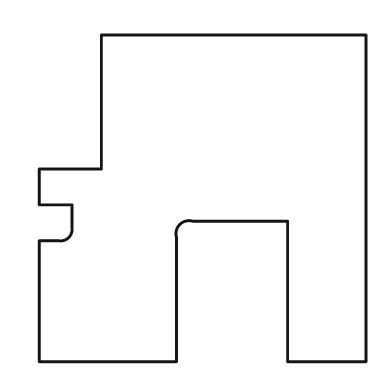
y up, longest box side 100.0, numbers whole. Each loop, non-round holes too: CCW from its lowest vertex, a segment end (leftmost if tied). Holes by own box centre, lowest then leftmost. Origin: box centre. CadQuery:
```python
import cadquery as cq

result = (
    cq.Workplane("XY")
    .moveTo(-50.0, -50.0)
    .lineTo(-8.0, -50.0)
    .lineTo(-8.0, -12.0)
    .threePointArc((-7.0, -8.0), (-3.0, -7.0))
    .lineTo(26.0, -7.0)
    .lineTo(26.0, -50.0)
    .lineTo(50.0, -50.0)
    .lineTo(50.0, 50.0)
    .lineTo(-31.0, 50.0)
    .lineTo(-31.0, 9.0)
    .lineTo(-50.0, 9.0)
    .lineTo(-50.0, -2.0)
    .lineTo(-40.0, -2.0)
    .lineTo(-40.0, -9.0)
    .threePointArc((-41.0, -12.0), (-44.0, -13.0))
    .lineTo(-50.0, -13.0)
    .close()
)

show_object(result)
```